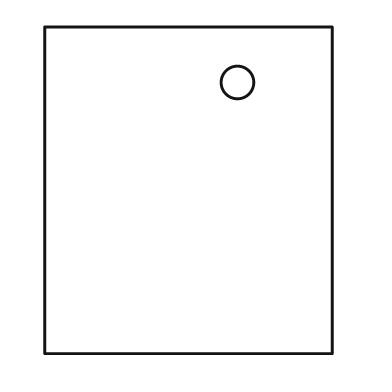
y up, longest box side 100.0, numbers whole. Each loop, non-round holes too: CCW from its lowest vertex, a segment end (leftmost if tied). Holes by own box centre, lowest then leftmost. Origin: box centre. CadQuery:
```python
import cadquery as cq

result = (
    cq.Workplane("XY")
    .moveTo(-44.0, -50.0)
    .lineTo(44.0, -50.0)
    .lineTo(44.0, 50.0)
    .lineTo(-44.0, 50.0)
    .close()
    .moveTo(15.0, 33.0)
    .circle(5.0)
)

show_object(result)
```